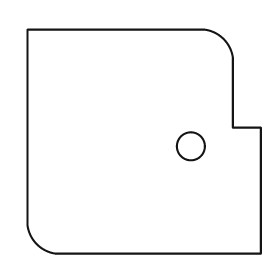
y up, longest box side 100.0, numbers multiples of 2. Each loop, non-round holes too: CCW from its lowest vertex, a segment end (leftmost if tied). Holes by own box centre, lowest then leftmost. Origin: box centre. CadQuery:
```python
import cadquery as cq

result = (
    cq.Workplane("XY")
    .moveTo(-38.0, -48.0)
    .lineTo(50.0, -48.0)
    .lineTo(50.0, 6.0)
    .lineTo(38.0, 6.0)
    .lineTo(38.0, 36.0)
    .threePointArc((34.0, 44.0), (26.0, 48.0))
    .lineTo(-50.0, 48.0)
    .lineTo(-50.0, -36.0)
    .threePointArc((-46.0, -44.0), (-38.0, -48.0))
    .close()
    .moveTo(20.0, -2.0)
    .circle(6.0)
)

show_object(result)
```